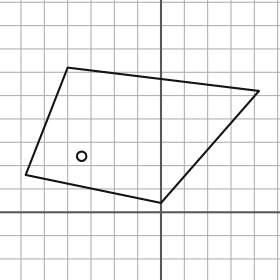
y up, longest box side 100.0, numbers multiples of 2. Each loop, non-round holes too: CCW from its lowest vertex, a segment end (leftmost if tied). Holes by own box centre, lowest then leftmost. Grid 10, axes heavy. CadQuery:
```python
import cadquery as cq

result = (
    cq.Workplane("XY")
    .moveTo(0.0, 4.0)
    .lineTo(42.0, 52.0)
    .lineTo(-40.0, 62.0)
    .lineTo(-58.0, 16.0)
    .close()
    .moveTo(-34.0, 24.0)
    .circle(2.0)
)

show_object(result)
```